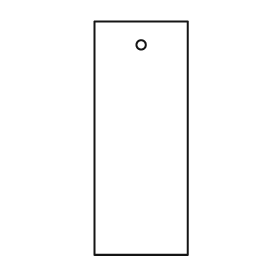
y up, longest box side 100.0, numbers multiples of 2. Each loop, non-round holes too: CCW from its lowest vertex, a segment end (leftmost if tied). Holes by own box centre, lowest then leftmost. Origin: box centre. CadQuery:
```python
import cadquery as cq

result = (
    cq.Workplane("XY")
    .moveTo(-20.0, -50.0)
    .lineTo(20.0, -50.0)
    .lineTo(20.0, 50.0)
    .lineTo(-20.0, 50.0)
    .close()
    .moveTo(0.0, 40.0)
    .circle(2.0)
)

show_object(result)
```